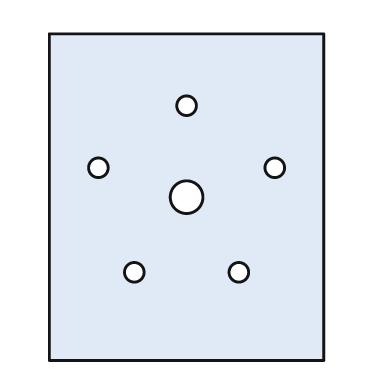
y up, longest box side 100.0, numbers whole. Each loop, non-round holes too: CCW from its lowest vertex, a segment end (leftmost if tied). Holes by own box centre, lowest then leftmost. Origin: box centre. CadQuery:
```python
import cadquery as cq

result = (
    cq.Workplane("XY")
    .moveTo(-42.0, -50.0)
    .lineTo(42.0, -50.0)
    .lineTo(42.0, 50.0)
    .lineTo(-42.0, 50.0)
    .close()
    .moveTo(-16.0, -23.0)
    .circle(3.0)
    .moveTo(16.0, -23.0)
    .circle(3.0)
    .moveTo(0.0, 0.0)
    .circle(5.0)
    .moveTo(-27.0, 9.0)
    .circle(3.0)
    .moveTo(27.0, 9.0)
    .circle(3.0)
    .moveTo(0.0, 28.0)
    .circle(3.0)
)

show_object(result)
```